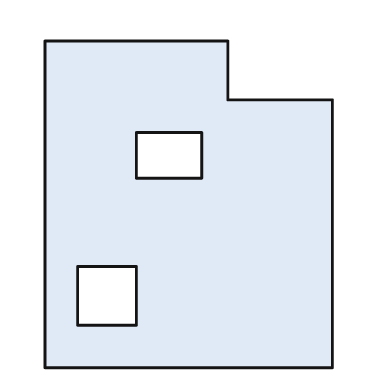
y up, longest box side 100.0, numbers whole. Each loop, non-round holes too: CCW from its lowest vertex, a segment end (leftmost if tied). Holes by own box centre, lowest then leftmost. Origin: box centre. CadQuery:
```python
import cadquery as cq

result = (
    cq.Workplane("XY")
    .moveTo(-44.0, -50.0)
    .lineTo(44.0, -50.0)
    .lineTo(44.0, 32.0)
    .lineTo(12.0, 32.0)
    .lineTo(12.0, 50.0)
    .lineTo(-44.0, 50.0)
    .close()
    .moveTo(-34.0, -37.0)
    .lineTo(-16.0, -37.0)
    .lineTo(-16.0, -19.0)
    .lineTo(-34.0, -19.0)
    .close()
    .moveTo(-16.0, 8.0)
    .lineTo(4.0, 8.0)
    .lineTo(4.0, 22.0)
    .lineTo(-16.0, 22.0)
    .close()
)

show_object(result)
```